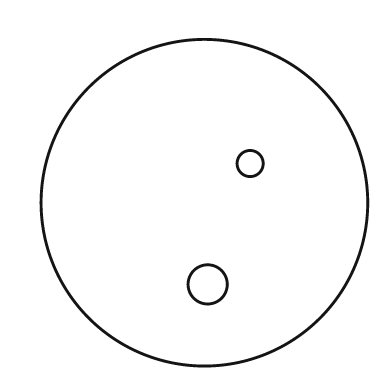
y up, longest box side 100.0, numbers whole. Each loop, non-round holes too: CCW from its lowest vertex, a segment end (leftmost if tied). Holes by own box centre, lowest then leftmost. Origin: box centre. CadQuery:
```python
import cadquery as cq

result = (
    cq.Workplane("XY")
    .moveTo(0.0, 0.0)
    .circle(50.0)
    .moveTo(1.0, -25.0)
    .circle(6.0)
    .moveTo(14.0, 12.0)
    .circle(4.0)
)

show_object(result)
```